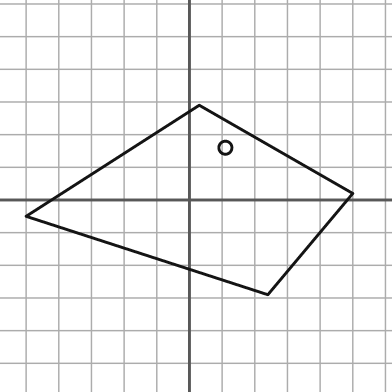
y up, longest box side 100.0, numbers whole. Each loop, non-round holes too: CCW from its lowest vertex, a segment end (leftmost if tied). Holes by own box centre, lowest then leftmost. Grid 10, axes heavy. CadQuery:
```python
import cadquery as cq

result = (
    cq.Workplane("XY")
    .moveTo(24.0, -29.0)
    .lineTo(50.0, 2.0)
    .lineTo(3.0, 29.0)
    .lineTo(-50.0, -5.0)
    .close()
    .moveTo(11.0, 16.0)
    .circle(2.0)
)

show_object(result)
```